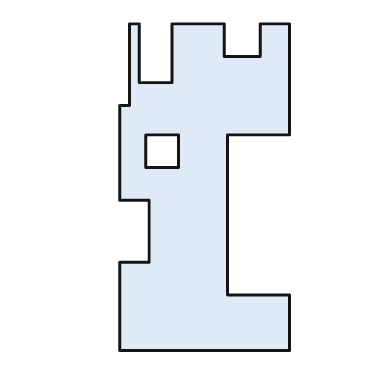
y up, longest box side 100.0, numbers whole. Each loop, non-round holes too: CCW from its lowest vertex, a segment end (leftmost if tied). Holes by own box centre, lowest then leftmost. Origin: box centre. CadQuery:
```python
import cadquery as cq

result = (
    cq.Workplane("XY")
    .moveTo(-26.0, -50.0)
    .lineTo(26.0, -50.0)
    .lineTo(26.0, -33.0)
    .lineTo(7.0, -33.0)
    .lineTo(7.0, 16.0)
    .lineTo(26.0, 16.0)
    .lineTo(26.0, 50.0)
    .lineTo(17.0, 50.0)
    .lineTo(17.0, 40.0)
    .lineTo(6.0, 40.0)
    .lineTo(6.0, 50.0)
    .lineTo(-10.0, 50.0)
    .lineTo(-10.0, 32.0)
    .lineTo(-20.0, 32.0)
    .lineTo(-20.0, 50.0)
    .lineTo(-23.0, 50.0)
    .lineTo(-23.0, 25.0)
    .lineTo(-26.0, 25.0)
    .lineTo(-26.0, -4.0)
    .lineTo(-17.0, -4.0)
    .lineTo(-17.0, -23.0)
    .lineTo(-26.0, -23.0)
    .close()
    .moveTo(-18.0, 6.0)
    .lineTo(-8.0, 6.0)
    .lineTo(-8.0, 16.0)
    .lineTo(-18.0, 16.0)
    .close()
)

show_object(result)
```